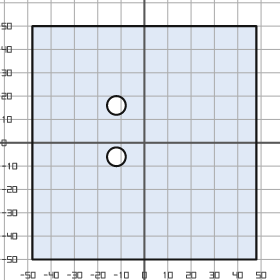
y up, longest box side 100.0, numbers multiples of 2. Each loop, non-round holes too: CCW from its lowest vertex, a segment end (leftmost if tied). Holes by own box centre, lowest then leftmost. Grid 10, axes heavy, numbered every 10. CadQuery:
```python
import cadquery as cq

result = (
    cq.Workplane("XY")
    .moveTo(-48.0, -50.0)
    .lineTo(48.0, -50.0)
    .lineTo(48.0, 50.0)
    .lineTo(-48.0, 50.0)
    .close()
    .moveTo(-12.0, -6.0)
    .circle(4.0)
    .moveTo(-12.0, 16.0)
    .circle(4.0)
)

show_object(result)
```